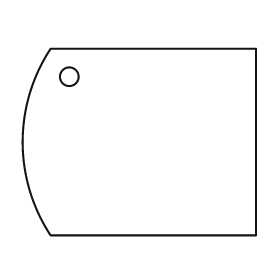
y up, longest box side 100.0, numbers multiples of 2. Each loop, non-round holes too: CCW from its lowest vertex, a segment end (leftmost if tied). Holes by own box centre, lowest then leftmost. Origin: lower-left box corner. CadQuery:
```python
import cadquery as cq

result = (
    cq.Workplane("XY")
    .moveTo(12.0, 0.0)
    .lineTo(100.0, 0.0)
    .lineTo(100.0, 80.0)
    .lineTo(12.0, 80.0)
    .threePointArc((0.0, 40.0), (12.0, 0.0))
    .close()
    .moveTo(20.0, 68.0)
    .circle(4.0)
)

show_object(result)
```